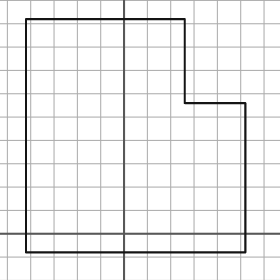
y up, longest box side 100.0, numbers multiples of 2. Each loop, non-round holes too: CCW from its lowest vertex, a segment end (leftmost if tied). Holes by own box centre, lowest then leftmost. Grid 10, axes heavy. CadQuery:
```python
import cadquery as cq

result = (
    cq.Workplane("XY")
    .moveTo(-42.0, -8.0)
    .lineTo(52.0, -8.0)
    .lineTo(52.0, 56.0)
    .lineTo(26.0, 56.0)
    .lineTo(26.0, 92.0)
    .lineTo(-42.0, 92.0)
    .close()
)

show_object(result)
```